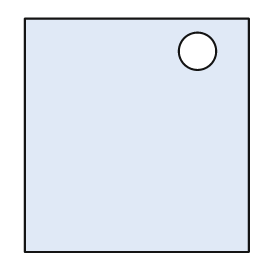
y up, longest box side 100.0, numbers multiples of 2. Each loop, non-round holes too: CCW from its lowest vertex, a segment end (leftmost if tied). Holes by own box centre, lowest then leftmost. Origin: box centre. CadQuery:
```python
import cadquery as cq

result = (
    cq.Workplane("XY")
    .moveTo(-48.0, -50.0)
    .lineTo(48.0, -50.0)
    .lineTo(48.0, 50.0)
    .lineTo(-48.0, 50.0)
    .close()
    .moveTo(26.0, 36.0)
    .circle(8.0)
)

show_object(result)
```